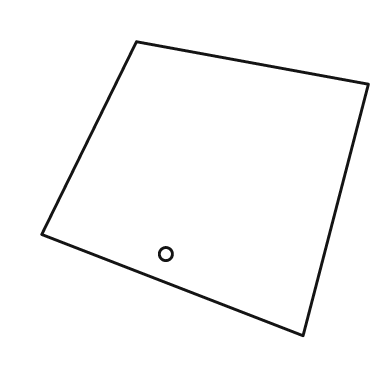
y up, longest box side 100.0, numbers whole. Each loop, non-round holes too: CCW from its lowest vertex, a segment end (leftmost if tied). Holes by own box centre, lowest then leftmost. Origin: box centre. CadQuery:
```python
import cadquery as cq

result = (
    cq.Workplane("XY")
    .moveTo(30.0, -45.0)
    .lineTo(50.0, 32.0)
    .lineTo(-21.0, 45.0)
    .lineTo(-50.0, -14.0)
    .close()
    .moveTo(-12.0, -20.0)
    .circle(2.0)
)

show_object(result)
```